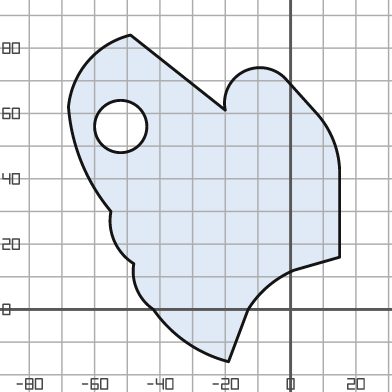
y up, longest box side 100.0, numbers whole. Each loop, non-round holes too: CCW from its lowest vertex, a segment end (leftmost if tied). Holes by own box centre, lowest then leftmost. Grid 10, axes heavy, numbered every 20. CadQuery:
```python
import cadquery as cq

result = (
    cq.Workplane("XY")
    .moveTo(-19.0, -16.0)
    .lineTo(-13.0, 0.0)
    .threePointArc((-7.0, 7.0), (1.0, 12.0))
    .lineTo(15.0, 16.0)
    .lineTo(15.0, 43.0)
    .threePointArc((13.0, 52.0), (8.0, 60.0))
    .lineTo(-1.0, 70.0)
    .threePointArc((-14.0, 73.0), (-20.0, 61.0))
    .lineTo(-49.0, 84.0)
    .threePointArc((-62.0, 76.0), (-68.0, 62.0))
    .threePointArc((-64.0, 45.0), (-55.0, 30.0))
    .threePointArc((-54.0, 21.0), (-48.0, 14.0))
    .threePointArc((-47.0, 6.0), (-42.0, 0.0))
    .threePointArc((-32.0, -10.0), (-19.0, -16.0))
    .close()
    .moveTo(-52.0, 56.0)
    .circle(8.0)
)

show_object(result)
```